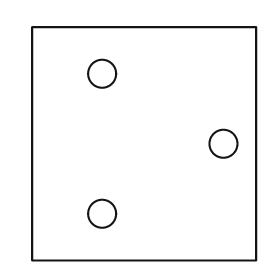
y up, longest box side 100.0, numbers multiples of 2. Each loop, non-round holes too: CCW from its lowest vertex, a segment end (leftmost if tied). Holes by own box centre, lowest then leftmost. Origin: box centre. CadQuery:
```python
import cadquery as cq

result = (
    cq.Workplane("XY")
    .moveTo(-48.0, -50.0)
    .lineTo(48.0, -50.0)
    .lineTo(48.0, 50.0)
    .lineTo(-48.0, 50.0)
    .close()
    .moveTo(-18.0, -30.0)
    .circle(6.0)
    .moveTo(34.0, 0.0)
    .circle(6.0)
    .moveTo(-18.0, 30.0)
    .circle(6.0)
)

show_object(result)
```